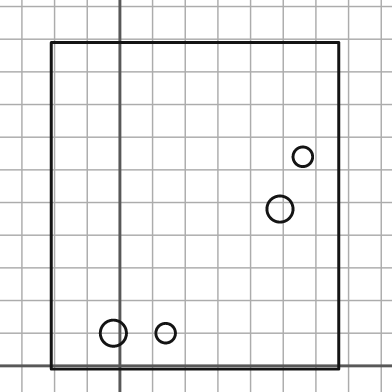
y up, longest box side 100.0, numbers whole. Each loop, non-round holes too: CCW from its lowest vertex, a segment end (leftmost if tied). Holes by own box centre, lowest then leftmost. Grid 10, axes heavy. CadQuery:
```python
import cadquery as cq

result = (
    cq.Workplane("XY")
    .moveTo(-21.0, -1.0)
    .lineTo(67.0, -1.0)
    .lineTo(67.0, 99.0)
    .lineTo(-21.0, 99.0)
    .close()
    .moveTo(-2.0, 10.0)
    .circle(4.0)
    .moveTo(14.0, 10.0)
    .circle(3.0)
    .moveTo(49.0, 48.0)
    .circle(4.0)
    .moveTo(56.0, 64.0)
    .circle(3.0)
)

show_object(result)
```